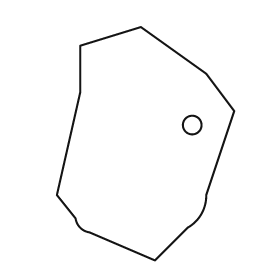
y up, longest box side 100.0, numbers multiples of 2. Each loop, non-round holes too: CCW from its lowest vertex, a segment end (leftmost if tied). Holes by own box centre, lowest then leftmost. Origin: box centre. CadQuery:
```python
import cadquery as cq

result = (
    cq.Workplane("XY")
    .moveTo(4.0, -50.0)
    .lineTo(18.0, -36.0)
    .threePointArc((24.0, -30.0), (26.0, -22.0))
    .lineTo(38.0, 14.0)
    .lineTo(26.0, 30.0)
    .lineTo(-2.0, 50.0)
    .lineTo(-28.0, 42.0)
    .lineTo(-28.0, 22.0)
    .lineTo(-38.0, -22.0)
    .lineTo(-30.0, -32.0)
    .threePointArc((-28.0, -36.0), (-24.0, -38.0))
    .close()
    .moveTo(20.0, 8.0)
    .circle(4.0)
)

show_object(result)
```